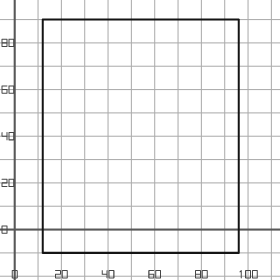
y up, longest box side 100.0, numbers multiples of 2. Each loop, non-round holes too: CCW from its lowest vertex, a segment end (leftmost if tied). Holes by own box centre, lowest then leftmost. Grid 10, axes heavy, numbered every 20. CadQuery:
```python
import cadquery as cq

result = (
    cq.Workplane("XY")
    .moveTo(12.0, -10.0)
    .lineTo(96.0, -10.0)
    .lineTo(96.0, 90.0)
    .lineTo(12.0, 90.0)
    .close()
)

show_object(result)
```